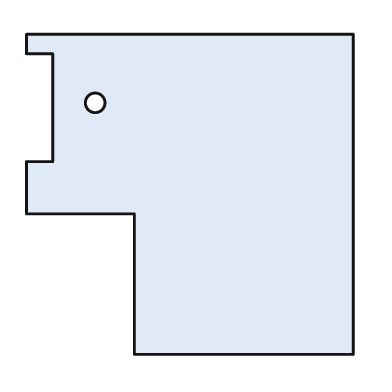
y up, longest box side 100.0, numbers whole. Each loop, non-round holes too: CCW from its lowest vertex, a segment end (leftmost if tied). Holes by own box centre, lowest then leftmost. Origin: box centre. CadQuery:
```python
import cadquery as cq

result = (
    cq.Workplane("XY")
    .moveTo(-17.0, -49.0)
    .lineTo(50.0, -49.0)
    .lineTo(50.0, 49.0)
    .lineTo(-50.0, 49.0)
    .lineTo(-50.0, 43.0)
    .lineTo(-42.0, 43.0)
    .lineTo(-42.0, 10.0)
    .lineTo(-50.0, 10.0)
    .lineTo(-50.0, -6.0)
    .lineTo(-17.0, -6.0)
    .close()
    .moveTo(-29.0, 28.0)
    .circle(3.0)
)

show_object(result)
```